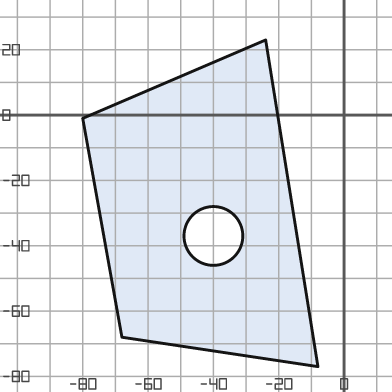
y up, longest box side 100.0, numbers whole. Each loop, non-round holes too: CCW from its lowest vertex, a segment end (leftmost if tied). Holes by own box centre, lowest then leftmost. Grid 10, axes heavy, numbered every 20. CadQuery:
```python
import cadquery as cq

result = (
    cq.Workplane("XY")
    .moveTo(-8.0, -77.0)
    .lineTo(-24.0, 23.0)
    .lineTo(-80.0, -1.0)
    .lineTo(-68.0, -68.0)
    .close()
    .moveTo(-40.0, -37.0)
    .circle(9.0)
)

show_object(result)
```